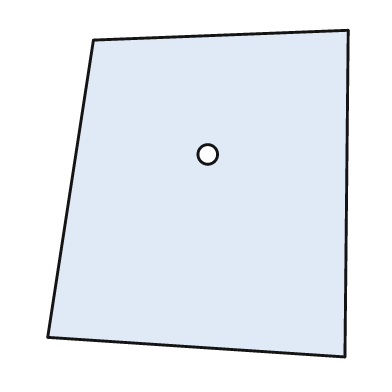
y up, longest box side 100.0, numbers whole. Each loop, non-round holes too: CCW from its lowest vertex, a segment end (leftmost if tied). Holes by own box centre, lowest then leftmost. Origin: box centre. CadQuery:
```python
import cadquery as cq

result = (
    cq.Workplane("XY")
    .moveTo(45.0, -50.0)
    .lineTo(46.0, 50.0)
    .lineTo(-32.0, 47.0)
    .lineTo(-46.0, -44.0)
    .close()
    .moveTo(3.0, 12.0)
    .circle(3.0)
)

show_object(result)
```